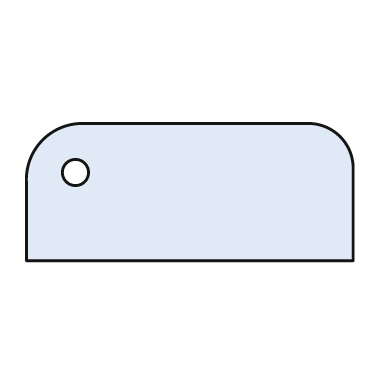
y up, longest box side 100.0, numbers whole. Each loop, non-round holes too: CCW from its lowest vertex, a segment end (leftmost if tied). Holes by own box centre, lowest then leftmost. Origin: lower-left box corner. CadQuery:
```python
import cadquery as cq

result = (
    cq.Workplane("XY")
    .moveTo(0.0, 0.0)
    .lineTo(100.0, 0.0)
    .lineTo(100.0, 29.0)
    .threePointArc((96.0, 38.0), (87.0, 42.0))
    .lineTo(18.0, 42.0)
    .threePointArc((5.0, 37.0), (0.0, 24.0))
    .close()
    .moveTo(15.0, 27.0)
    .circle(4.0)
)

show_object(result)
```